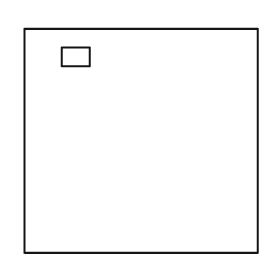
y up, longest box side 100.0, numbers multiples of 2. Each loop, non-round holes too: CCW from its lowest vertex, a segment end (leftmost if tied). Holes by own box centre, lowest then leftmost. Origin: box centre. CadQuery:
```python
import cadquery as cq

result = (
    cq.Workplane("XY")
    .moveTo(-50.0, -48.0)
    .lineTo(50.0, -48.0)
    .lineTo(50.0, 48.0)
    .lineTo(-50.0, 48.0)
    .close()
    .moveTo(-34.0, 32.0)
    .lineTo(-22.0, 32.0)
    .lineTo(-22.0, 40.0)
    .lineTo(-34.0, 40.0)
    .close()
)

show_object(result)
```